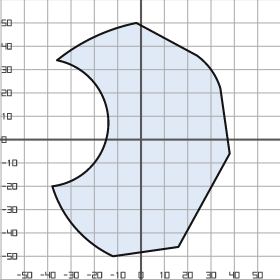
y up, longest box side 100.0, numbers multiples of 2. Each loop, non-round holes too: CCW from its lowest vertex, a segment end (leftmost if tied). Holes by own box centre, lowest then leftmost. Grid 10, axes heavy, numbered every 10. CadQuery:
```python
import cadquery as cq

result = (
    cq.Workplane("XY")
    .moveTo(-12.0, -50.0)
    .lineTo(16.0, -46.0)
    .lineTo(38.0, -6.0)
    .lineTo(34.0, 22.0)
    .threePointArc((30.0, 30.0), (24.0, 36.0))
    .lineTo(-2.0, 50.0)
    .threePointArc((-20.0, 44.0), (-36.0, 34.0))
    .threePointArc((-14.0, 6.0), (-38.0, -20.0))
    .threePointArc((-28.0, -38.0), (-12.0, -50.0))
    .close()
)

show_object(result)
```